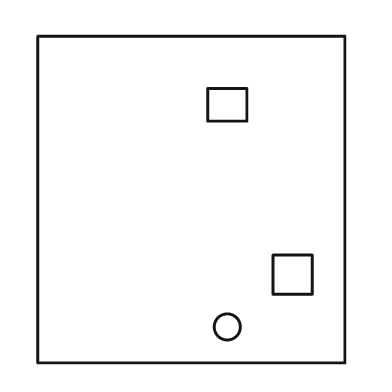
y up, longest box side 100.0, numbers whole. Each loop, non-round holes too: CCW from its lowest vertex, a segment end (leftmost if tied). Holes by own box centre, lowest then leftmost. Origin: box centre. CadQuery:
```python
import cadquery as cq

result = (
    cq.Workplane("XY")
    .moveTo(-47.0, -50.0)
    .lineTo(47.0, -50.0)
    .lineTo(47.0, 50.0)
    .lineTo(-47.0, 50.0)
    .close()
    .moveTo(11.0, -39.0)
    .circle(4.0)
    .moveTo(25.0, -29.0)
    .lineTo(37.0, -29.0)
    .lineTo(37.0, -17.0)
    .lineTo(25.0, -17.0)
    .close()
    .moveTo(5.0, 24.0)
    .lineTo(17.0, 24.0)
    .lineTo(17.0, 34.0)
    .lineTo(5.0, 34.0)
    .close()
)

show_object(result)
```